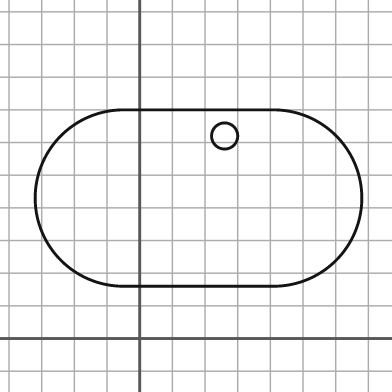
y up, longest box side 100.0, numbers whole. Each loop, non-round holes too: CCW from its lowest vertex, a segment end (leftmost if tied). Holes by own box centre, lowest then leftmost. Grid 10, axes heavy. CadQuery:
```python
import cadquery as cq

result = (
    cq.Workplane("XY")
    .moveTo(-5.0, 16.0)
    .lineTo(41.0, 16.0)
    .threePointArc((68.0, 43.0), (41.0, 70.0))
    .lineTo(-5.0, 70.0)
    .threePointArc((-32.0, 43.0), (-5.0, 16.0))
    .close()
    .moveTo(26.0, 62.0)
    .circle(4.0)
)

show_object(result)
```